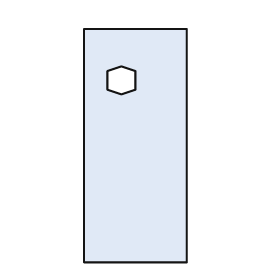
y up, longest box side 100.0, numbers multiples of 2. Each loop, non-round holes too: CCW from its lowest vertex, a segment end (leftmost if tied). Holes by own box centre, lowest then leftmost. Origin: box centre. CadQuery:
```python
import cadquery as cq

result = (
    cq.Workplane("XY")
    .moveTo(-22.0, -50.0)
    .lineTo(22.0, -50.0)
    .lineTo(22.0, 50.0)
    .lineTo(-22.0, 50.0)
    .close()
    .moveTo(-6.0, 22.0)
    .lineTo(0.0, 24.0)
    .lineTo(0.0, 32.0)
    .lineTo(-6.0, 34.0)
    .lineTo(-12.0, 32.0)
    .lineTo(-12.0, 24.0)
    .close()
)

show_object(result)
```